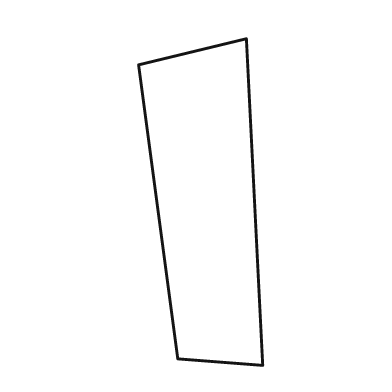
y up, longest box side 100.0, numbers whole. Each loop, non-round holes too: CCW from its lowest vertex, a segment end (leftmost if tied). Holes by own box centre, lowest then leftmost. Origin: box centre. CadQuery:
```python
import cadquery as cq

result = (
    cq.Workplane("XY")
    .moveTo(19.0, -50.0)
    .lineTo(14.0, 50.0)
    .lineTo(-19.0, 42.0)
    .lineTo(-7.0, -48.0)
    .close()
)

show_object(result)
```